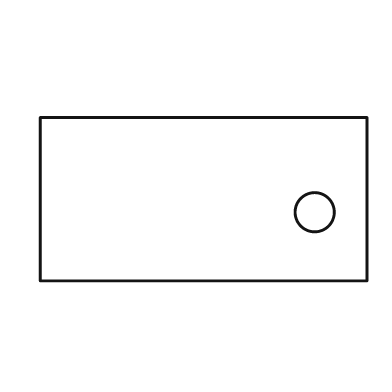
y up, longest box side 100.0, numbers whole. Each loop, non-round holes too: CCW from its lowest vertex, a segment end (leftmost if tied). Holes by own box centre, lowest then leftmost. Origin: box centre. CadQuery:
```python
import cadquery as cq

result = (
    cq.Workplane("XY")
    .moveTo(-50.0, -25.0)
    .lineTo(50.0, -25.0)
    .lineTo(50.0, 25.0)
    .lineTo(-50.0, 25.0)
    .close()
    .moveTo(34.0, -4.0)
    .circle(6.0)
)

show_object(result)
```